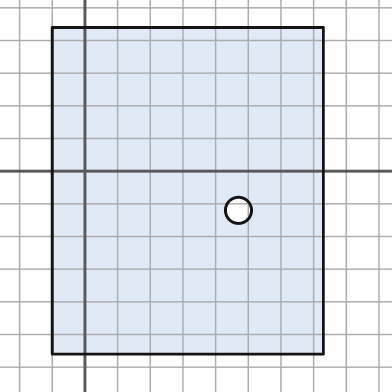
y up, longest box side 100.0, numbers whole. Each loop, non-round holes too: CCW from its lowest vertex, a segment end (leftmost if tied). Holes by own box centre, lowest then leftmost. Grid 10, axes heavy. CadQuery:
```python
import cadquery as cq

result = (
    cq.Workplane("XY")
    .moveTo(-10.0, -56.0)
    .lineTo(73.0, -56.0)
    .lineTo(73.0, 44.0)
    .lineTo(-10.0, 44.0)
    .close()
    .moveTo(47.0, -12.0)
    .circle(4.0)
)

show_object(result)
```